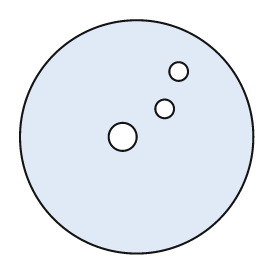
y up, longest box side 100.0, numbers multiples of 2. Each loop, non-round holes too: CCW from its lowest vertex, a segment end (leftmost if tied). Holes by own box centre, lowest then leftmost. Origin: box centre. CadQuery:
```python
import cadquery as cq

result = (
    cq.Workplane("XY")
    .moveTo(0.0, 0.0)
    .circle(50.0)
    .moveTo(-6.0, 0.0)
    .circle(6.0)
    .moveTo(12.0, 12.0)
    .circle(4.0)
    .moveTo(18.0, 28.0)
    .circle(4.0)
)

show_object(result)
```